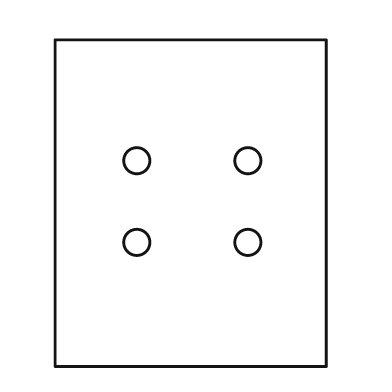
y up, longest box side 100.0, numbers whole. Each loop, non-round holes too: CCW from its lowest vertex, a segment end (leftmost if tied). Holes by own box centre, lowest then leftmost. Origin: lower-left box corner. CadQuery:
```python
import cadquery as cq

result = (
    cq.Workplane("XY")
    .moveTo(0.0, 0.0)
    .lineTo(83.0, 0.0)
    .lineTo(83.0, 100.0)
    .lineTo(0.0, 100.0)
    .close()
    .moveTo(25.0, 38.0)
    .circle(4.0)
    .moveTo(59.0, 38.0)
    .circle(4.0)
    .moveTo(25.0, 63.0)
    .circle(4.0)
    .moveTo(59.0, 63.0)
    .circle(4.0)
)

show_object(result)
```